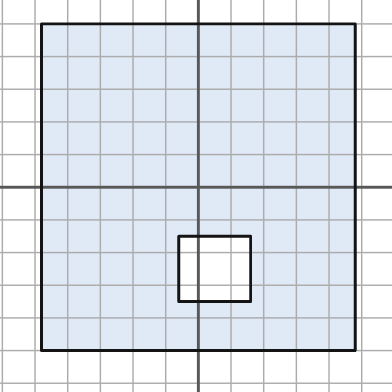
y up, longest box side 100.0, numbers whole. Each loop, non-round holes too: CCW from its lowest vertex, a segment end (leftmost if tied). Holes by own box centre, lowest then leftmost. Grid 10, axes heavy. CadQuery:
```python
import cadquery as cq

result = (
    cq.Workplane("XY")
    .moveTo(-48.0, -50.0)
    .lineTo(48.0, -50.0)
    .lineTo(48.0, 50.0)
    .lineTo(-48.0, 50.0)
    .close()
    .moveTo(-6.0, -35.0)
    .lineTo(16.0, -35.0)
    .lineTo(16.0, -15.0)
    .lineTo(-6.0, -15.0)
    .close()
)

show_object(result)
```